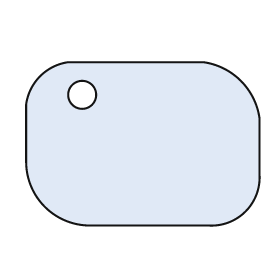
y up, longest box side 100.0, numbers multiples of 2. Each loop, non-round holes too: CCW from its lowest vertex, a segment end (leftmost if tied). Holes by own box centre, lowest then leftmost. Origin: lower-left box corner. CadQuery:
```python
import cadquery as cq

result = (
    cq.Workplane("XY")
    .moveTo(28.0, 0.0)
    .lineTo(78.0, 0.0)
    .threePointArc((94.0, 6.0), (100.0, 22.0))
    .lineTo(100.0, 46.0)
    .threePointArc((92.0, 62.0), (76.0, 70.0))
    .lineTo(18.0, 70.0)
    .threePointArc((6.0, 64.0), (0.0, 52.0))
    .lineTo(0.0, 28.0)
    .threePointArc((8.0, 8.0), (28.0, 0.0))
    .close()
    .moveTo(24.0, 56.0)
    .circle(6.0)
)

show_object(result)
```